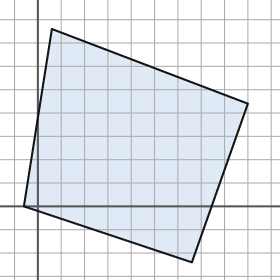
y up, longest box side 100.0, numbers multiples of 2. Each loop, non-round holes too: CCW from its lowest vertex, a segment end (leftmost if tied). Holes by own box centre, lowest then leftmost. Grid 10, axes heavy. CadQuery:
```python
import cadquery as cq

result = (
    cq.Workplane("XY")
    .moveTo(66.0, -24.0)
    .lineTo(90.0, 44.0)
    .lineTo(6.0, 76.0)
    .lineTo(-6.0, 0.0)
    .close()
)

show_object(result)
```